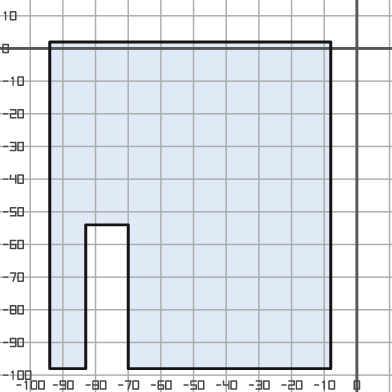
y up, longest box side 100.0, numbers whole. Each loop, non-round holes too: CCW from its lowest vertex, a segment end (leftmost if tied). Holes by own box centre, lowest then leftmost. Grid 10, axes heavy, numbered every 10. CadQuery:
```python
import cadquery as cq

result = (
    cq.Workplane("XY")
    .moveTo(-94.0, -98.0)
    .lineTo(-83.0, -98.0)
    .lineTo(-83.0, -54.0)
    .lineTo(-70.0, -54.0)
    .lineTo(-70.0, -98.0)
    .lineTo(-8.0, -98.0)
    .lineTo(-8.0, 2.0)
    .lineTo(-94.0, 2.0)
    .close()
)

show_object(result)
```